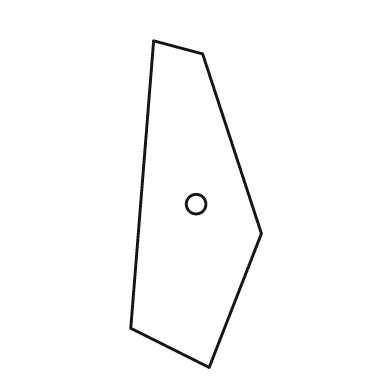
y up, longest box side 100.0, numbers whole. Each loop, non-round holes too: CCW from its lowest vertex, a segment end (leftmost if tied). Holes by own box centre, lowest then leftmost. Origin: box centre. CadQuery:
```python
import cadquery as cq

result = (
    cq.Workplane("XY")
    .moveTo(4.0, -50.0)
    .lineTo(20.0, -9.0)
    .lineTo(2.0, 46.0)
    .lineTo(-13.0, 50.0)
    .lineTo(-20.0, -38.0)
    .close()
    .moveTo(0.0, 0.0)
    .circle(3.0)
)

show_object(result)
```